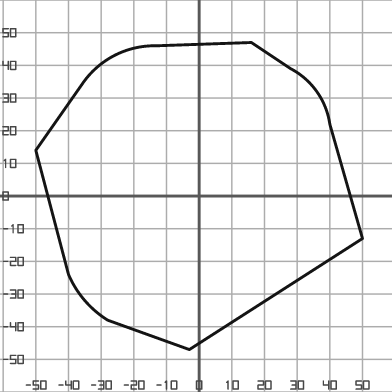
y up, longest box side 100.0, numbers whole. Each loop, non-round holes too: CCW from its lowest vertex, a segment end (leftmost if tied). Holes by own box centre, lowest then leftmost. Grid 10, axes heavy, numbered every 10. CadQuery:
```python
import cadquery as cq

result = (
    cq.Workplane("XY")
    .moveTo(-3.0, -47.0)
    .lineTo(50.0, -13.0)
    .lineTo(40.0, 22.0)
    .threePointArc((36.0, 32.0), (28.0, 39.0))
    .lineTo(16.0, 47.0)
    .lineTo(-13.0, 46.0)
    .threePointArc((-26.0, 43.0), (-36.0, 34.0))
    .lineTo(-50.0, 14.0)
    .lineTo(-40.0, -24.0)
    .threePointArc((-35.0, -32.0), (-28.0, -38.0))
    .close()
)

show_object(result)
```